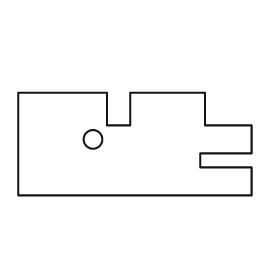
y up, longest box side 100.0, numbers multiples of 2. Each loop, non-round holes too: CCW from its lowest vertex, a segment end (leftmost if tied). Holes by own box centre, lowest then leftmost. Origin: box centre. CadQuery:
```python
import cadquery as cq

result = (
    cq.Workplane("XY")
    .moveTo(-50.0, -22.0)
    .lineTo(50.0, -22.0)
    .lineTo(50.0, -10.0)
    .lineTo(28.0, -10.0)
    .lineTo(28.0, -4.0)
    .lineTo(50.0, -4.0)
    .lineTo(50.0, 8.0)
    .lineTo(30.0, 8.0)
    .lineTo(30.0, 22.0)
    .lineTo(-2.0, 22.0)
    .lineTo(-2.0, 8.0)
    .lineTo(-12.0, 8.0)
    .lineTo(-12.0, 22.0)
    .lineTo(-50.0, 22.0)
    .close()
    .moveTo(-18.0, 2.0)
    .circle(4.0)
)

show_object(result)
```